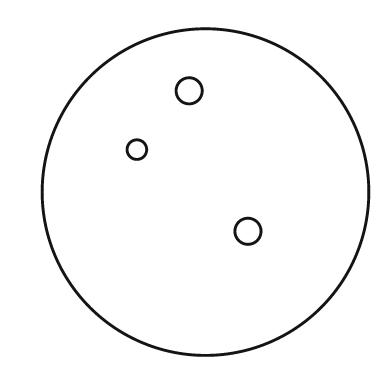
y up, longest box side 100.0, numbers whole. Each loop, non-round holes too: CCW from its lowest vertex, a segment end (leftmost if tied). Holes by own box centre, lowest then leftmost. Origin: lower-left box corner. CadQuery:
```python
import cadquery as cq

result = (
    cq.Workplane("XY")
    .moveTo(50.0, 50.0)
    .circle(50.0)
    .moveTo(63.0, 38.0)
    .circle(4.0)
    .moveTo(29.0, 63.0)
    .circle(3.0)
    .moveTo(45.0, 81.0)
    .circle(4.0)
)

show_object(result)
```